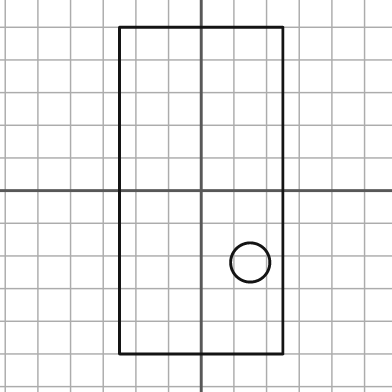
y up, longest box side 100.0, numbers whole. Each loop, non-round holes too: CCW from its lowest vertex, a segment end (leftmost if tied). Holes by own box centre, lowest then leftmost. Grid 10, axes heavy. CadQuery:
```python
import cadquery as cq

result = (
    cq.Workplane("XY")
    .moveTo(-25.0, -50.0)
    .lineTo(25.0, -50.0)
    .lineTo(25.0, 50.0)
    .lineTo(-25.0, 50.0)
    .close()
    .moveTo(15.0, -22.0)
    .circle(6.0)
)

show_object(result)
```